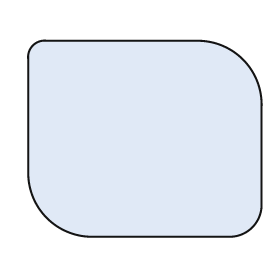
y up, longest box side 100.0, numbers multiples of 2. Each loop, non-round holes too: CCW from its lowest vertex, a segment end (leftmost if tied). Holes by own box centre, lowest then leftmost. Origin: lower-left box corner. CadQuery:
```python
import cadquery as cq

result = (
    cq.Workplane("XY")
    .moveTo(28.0, 0.0)
    .lineTo(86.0, 0.0)
    .threePointArc((96.0, 4.0), (100.0, 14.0))
    .lineTo(100.0, 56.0)
    .threePointArc((92.0, 76.0), (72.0, 84.0))
    .lineTo(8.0, 84.0)
    .threePointArc((2.0, 82.0), (0.0, 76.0))
    .lineTo(0.0, 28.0)
    .threePointArc((8.0, 8.0), (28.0, 0.0))
    .close()
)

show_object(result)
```